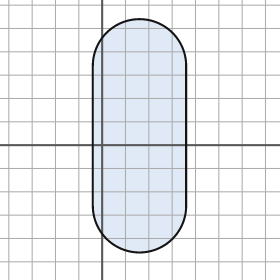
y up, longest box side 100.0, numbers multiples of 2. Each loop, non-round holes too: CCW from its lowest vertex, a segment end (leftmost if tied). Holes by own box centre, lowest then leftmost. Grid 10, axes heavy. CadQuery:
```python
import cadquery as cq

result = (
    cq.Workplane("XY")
    .moveTo(-4.0, -26.0)
    .threePointArc((16.0, -46.0), (36.0, -26.0))
    .lineTo(36.0, 34.0)
    .threePointArc((16.0, 54.0), (-4.0, 34.0))
    .close()
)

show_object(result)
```